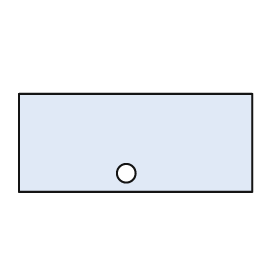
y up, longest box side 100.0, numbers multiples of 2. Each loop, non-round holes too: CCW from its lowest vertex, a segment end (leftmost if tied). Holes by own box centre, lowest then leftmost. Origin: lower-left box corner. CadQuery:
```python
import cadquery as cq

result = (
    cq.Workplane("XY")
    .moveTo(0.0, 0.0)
    .lineTo(100.0, 0.0)
    .lineTo(100.0, 42.0)
    .lineTo(0.0, 42.0)
    .close()
    .moveTo(46.0, 8.0)
    .circle(4.0)
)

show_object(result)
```